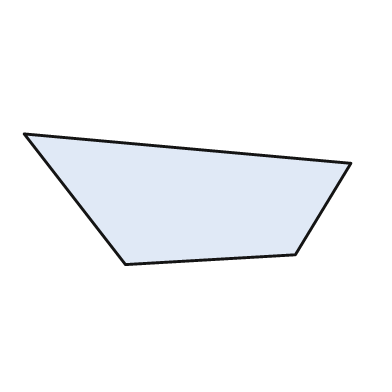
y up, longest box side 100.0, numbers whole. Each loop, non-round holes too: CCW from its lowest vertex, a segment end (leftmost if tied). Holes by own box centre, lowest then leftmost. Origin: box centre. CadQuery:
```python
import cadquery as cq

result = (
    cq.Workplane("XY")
    .moveTo(-19.0, -20.0)
    .lineTo(33.0, -17.0)
    .lineTo(50.0, 11.0)
    .lineTo(-50.0, 20.0)
    .close()
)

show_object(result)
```